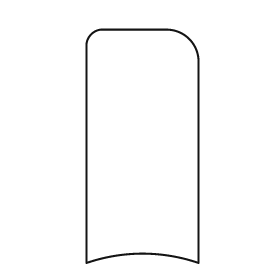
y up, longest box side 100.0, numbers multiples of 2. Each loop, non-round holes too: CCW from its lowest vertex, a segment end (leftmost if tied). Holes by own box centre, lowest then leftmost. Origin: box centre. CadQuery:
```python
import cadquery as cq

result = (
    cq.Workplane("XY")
    .moveTo(-24.0, -50.0)
    .threePointArc((0.0, -46.0), (24.0, -50.0))
    .lineTo(24.0, 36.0)
    .threePointArc((20.0, 46.0), (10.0, 50.0))
    .lineTo(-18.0, 50.0)
    .threePointArc((-22.0, 48.0), (-24.0, 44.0))
    .close()
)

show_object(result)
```